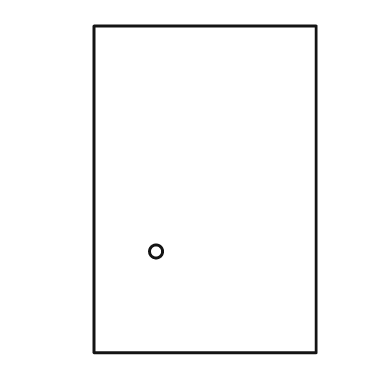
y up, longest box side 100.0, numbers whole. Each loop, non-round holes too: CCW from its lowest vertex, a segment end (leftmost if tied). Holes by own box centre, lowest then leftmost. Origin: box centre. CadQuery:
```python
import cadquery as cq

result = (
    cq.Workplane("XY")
    .moveTo(-34.0, -50.0)
    .lineTo(34.0, -50.0)
    .lineTo(34.0, 50.0)
    .lineTo(-34.0, 50.0)
    .close()
    .moveTo(-15.0, -19.0)
    .circle(2.0)
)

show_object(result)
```